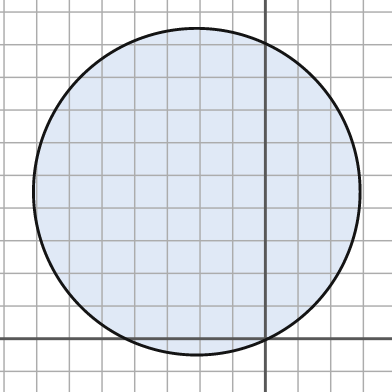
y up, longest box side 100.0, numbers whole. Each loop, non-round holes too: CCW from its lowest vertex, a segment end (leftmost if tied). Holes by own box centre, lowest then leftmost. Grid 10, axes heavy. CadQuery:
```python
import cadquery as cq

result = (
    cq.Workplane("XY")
    .moveTo(-21.0, 45.0)
    .circle(50.0)
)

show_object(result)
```